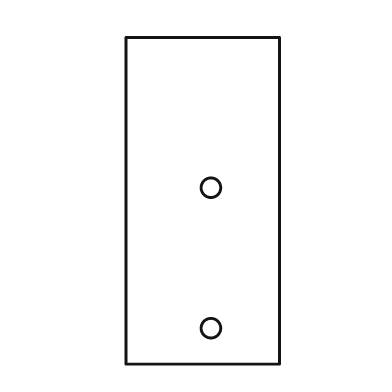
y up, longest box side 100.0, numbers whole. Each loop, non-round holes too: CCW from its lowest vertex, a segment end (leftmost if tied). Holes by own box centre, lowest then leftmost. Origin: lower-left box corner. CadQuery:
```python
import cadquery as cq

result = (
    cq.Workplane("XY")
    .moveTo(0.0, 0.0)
    .lineTo(47.0, 0.0)
    .lineTo(47.0, 100.0)
    .lineTo(0.0, 100.0)
    .close()
    .moveTo(26.0, 11.0)
    .circle(3.0)
    .moveTo(26.0, 54.0)
    .circle(3.0)
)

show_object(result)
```